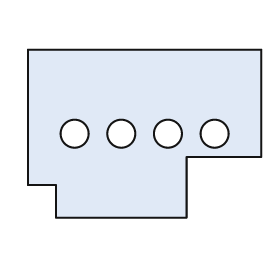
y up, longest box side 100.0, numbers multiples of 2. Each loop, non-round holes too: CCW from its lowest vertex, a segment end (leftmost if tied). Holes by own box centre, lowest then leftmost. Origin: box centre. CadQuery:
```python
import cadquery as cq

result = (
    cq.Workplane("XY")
    .moveTo(-38.0, -36.0)
    .lineTo(18.0, -36.0)
    .lineTo(18.0, -10.0)
    .lineTo(50.0, -10.0)
    .lineTo(50.0, 36.0)
    .lineTo(-50.0, 36.0)
    .lineTo(-50.0, -22.0)
    .lineTo(-38.0, -22.0)
    .close()
    .moveTo(-30.0, 0.0)
    .circle(6.0)
    .moveTo(-10.0, 0.0)
    .circle(6.0)
    .moveTo(10.0, 0.0)
    .circle(6.0)
    .moveTo(30.0, 0.0)
    .circle(6.0)
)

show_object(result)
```